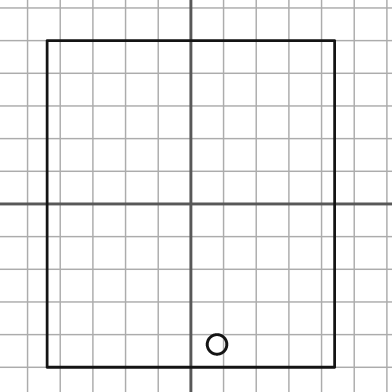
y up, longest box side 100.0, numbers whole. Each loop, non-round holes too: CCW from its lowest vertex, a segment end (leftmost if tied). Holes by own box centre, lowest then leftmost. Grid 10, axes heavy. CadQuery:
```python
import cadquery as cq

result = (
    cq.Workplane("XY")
    .moveTo(-44.0, -50.0)
    .lineTo(44.0, -50.0)
    .lineTo(44.0, 50.0)
    .lineTo(-44.0, 50.0)
    .close()
    .moveTo(8.0, -43.0)
    .circle(3.0)
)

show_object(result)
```